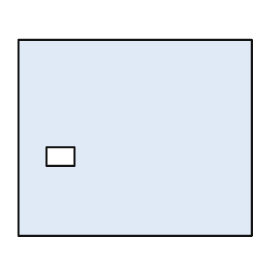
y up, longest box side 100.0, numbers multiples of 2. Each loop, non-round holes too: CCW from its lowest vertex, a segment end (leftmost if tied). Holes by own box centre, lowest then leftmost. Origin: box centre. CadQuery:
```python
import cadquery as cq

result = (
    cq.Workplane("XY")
    .moveTo(-50.0, -42.0)
    .lineTo(50.0, -42.0)
    .lineTo(50.0, 42.0)
    .lineTo(-50.0, 42.0)
    .close()
    .moveTo(-38.0, -12.0)
    .lineTo(-26.0, -12.0)
    .lineTo(-26.0, -4.0)
    .lineTo(-38.0, -4.0)
    .close()
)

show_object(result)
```